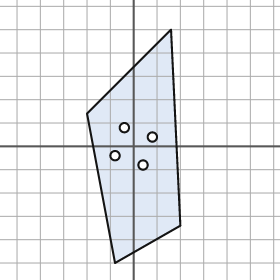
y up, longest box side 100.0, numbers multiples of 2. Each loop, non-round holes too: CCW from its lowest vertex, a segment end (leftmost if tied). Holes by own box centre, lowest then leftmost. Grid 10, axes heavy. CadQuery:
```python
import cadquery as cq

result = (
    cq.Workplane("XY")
    .moveTo(-8.0, -50.0)
    .lineTo(20.0, -34.0)
    .lineTo(16.0, 50.0)
    .lineTo(-20.0, 14.0)
    .close()
    .moveTo(4.0, -8.0)
    .circle(2.0)
    .moveTo(-8.0, -4.0)
    .circle(2.0)
    .moveTo(8.0, 4.0)
    .circle(2.0)
    .moveTo(-4.0, 8.0)
    .circle(2.0)
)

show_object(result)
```